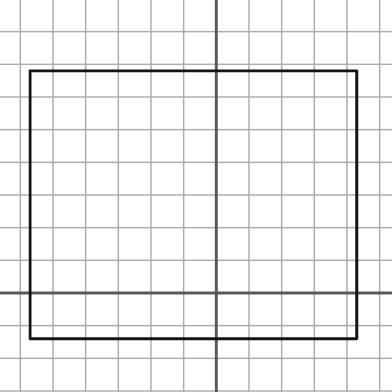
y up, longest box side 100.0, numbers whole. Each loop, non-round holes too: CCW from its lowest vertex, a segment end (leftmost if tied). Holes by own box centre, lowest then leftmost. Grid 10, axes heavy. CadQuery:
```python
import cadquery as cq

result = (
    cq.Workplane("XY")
    .moveTo(-57.0, -14.0)
    .lineTo(43.0, -14.0)
    .lineTo(43.0, 68.0)
    .lineTo(-57.0, 68.0)
    .close()
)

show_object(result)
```